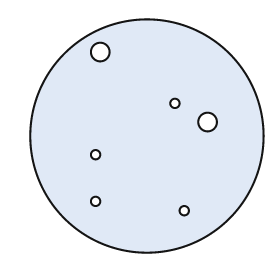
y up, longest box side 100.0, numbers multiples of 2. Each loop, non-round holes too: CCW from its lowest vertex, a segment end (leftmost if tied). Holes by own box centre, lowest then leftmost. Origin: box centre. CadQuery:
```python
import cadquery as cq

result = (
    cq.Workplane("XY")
    .moveTo(0.0, 0.0)
    .circle(50.0)
    .moveTo(16.0, -32.0)
    .circle(2.0)
    .moveTo(-22.0, -28.0)
    .circle(2.0)
    .moveTo(-22.0, -8.0)
    .circle(2.0)
    .moveTo(26.0, 6.0)
    .circle(4.0)
    .moveTo(12.0, 14.0)
    .circle(2.0)
    .moveTo(-20.0, 36.0)
    .circle(4.0)
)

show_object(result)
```